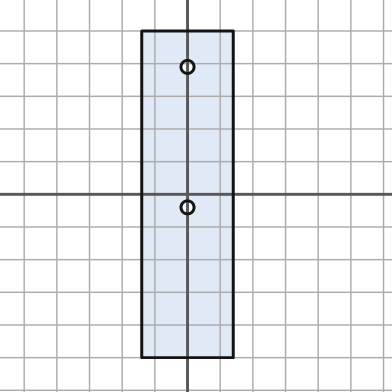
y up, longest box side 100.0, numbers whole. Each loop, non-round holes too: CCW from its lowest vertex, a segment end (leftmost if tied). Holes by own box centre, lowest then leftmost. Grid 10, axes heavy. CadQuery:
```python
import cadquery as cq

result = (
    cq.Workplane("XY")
    .moveTo(-14.0, -50.0)
    .lineTo(14.0, -50.0)
    .lineTo(14.0, 50.0)
    .lineTo(-14.0, 50.0)
    .close()
    .moveTo(0.0, -4.0)
    .circle(2.0)
    .moveTo(0.0, 39.0)
    .circle(2.0)
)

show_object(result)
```